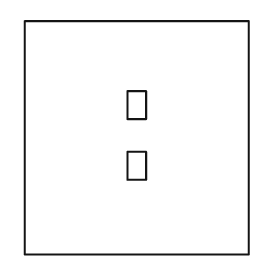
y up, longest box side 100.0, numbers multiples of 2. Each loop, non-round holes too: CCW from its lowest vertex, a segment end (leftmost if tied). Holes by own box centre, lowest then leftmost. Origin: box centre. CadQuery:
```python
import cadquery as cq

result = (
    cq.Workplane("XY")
    .moveTo(-48.0, -50.0)
    .lineTo(48.0, -50.0)
    .lineTo(48.0, 50.0)
    .lineTo(-48.0, 50.0)
    .close()
    .moveTo(-4.0, -18.0)
    .lineTo(4.0, -18.0)
    .lineTo(4.0, -6.0)
    .lineTo(-4.0, -6.0)
    .close()
    .moveTo(-4.0, 8.0)
    .lineTo(4.0, 8.0)
    .lineTo(4.0, 20.0)
    .lineTo(-4.0, 20.0)
    .close()
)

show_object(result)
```